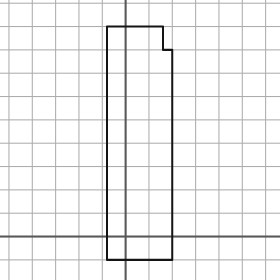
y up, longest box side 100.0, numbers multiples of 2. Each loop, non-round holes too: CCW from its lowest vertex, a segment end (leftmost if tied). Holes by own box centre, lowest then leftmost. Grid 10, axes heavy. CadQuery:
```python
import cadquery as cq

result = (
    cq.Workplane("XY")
    .moveTo(-8.0, -10.0)
    .lineTo(20.0, -10.0)
    .lineTo(20.0, 80.0)
    .lineTo(16.0, 80.0)
    .lineTo(16.0, 90.0)
    .lineTo(-8.0, 90.0)
    .close()
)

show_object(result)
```